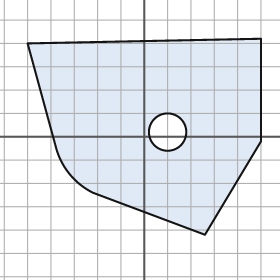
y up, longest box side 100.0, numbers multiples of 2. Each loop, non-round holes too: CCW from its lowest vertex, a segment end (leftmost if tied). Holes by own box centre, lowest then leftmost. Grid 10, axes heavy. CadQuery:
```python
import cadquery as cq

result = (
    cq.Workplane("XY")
    .moveTo(26.0, -42.0)
    .lineTo(50.0, -2.0)
    .lineTo(50.0, 42.0)
    .lineTo(-50.0, 40.0)
    .lineTo(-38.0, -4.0)
    .threePointArc((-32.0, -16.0), (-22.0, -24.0))
    .close()
    .moveTo(10.0, 2.0)
    .circle(8.0)
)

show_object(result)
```